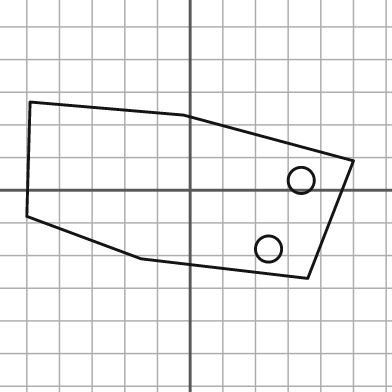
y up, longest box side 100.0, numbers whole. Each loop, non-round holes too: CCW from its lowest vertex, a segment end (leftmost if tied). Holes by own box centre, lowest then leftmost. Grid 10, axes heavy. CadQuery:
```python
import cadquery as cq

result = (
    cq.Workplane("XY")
    .moveTo(36.0, -27.0)
    .lineTo(50.0, 9.0)
    .lineTo(-2.0, 23.0)
    .lineTo(-49.0, 27.0)
    .lineTo(-50.0, -8.0)
    .lineTo(-15.0, -21.0)
    .close()
    .moveTo(24.0, -18.0)
    .circle(4.0)
    .moveTo(34.0, 3.0)
    .circle(4.0)
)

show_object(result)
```